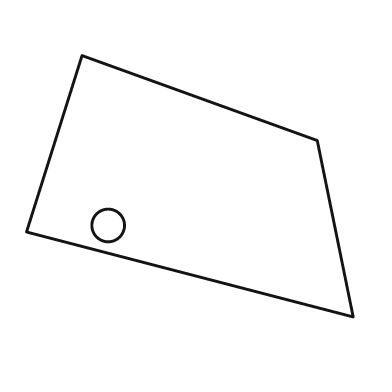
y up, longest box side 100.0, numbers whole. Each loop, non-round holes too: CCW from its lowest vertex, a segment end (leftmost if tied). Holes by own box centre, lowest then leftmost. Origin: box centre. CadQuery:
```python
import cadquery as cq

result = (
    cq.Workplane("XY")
    .moveTo(50.0, -40.0)
    .lineTo(39.0, 14.0)
    .lineTo(-33.0, 40.0)
    .lineTo(-50.0, -14.0)
    .close()
    .moveTo(-25.0, -12.0)
    .circle(5.0)
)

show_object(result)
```